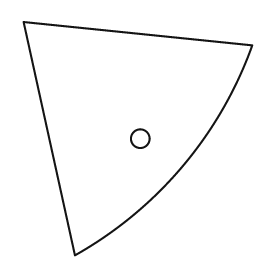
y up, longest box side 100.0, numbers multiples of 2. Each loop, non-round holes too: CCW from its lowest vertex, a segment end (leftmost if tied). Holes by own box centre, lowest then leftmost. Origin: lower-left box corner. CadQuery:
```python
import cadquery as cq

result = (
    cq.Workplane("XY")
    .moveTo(22.0, 0.0)
    .threePointArc((68.0, 38.0), (98.0, 90.0))
    .lineTo(0.0, 100.0)
    .close()
    .moveTo(50.0, 50.0)
    .circle(4.0)
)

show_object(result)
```